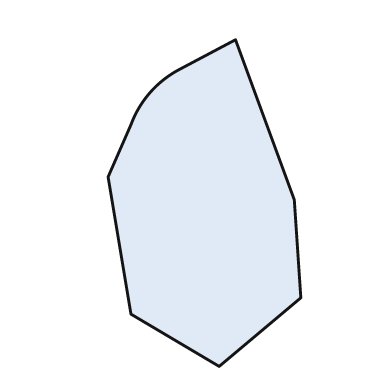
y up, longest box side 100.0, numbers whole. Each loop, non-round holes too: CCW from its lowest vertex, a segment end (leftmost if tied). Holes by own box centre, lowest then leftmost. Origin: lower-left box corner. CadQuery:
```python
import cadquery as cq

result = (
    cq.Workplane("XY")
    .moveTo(34.0, 0.0)
    .lineTo(59.0, 21.0)
    .lineTo(57.0, 51.0)
    .lineTo(39.0, 100.0)
    .lineTo(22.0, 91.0)
    .threePointArc((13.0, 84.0), (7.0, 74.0))
    .lineTo(0.0, 58.0)
    .lineTo(7.0, 16.0)
    .close()
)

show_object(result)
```